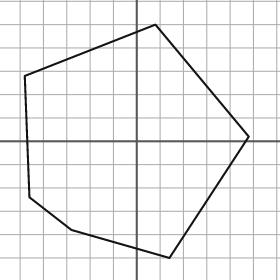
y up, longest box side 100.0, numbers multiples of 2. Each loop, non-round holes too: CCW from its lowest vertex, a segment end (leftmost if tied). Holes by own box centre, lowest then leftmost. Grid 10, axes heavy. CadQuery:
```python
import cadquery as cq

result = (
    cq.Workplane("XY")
    .moveTo(14.0, -50.0)
    .lineTo(48.0, 2.0)
    .lineTo(8.0, 50.0)
    .lineTo(-48.0, 28.0)
    .lineTo(-46.0, -24.0)
    .lineTo(-28.0, -38.0)
    .close()
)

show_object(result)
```